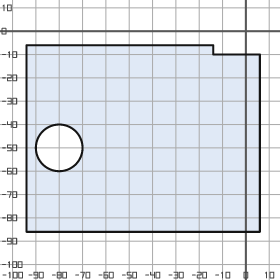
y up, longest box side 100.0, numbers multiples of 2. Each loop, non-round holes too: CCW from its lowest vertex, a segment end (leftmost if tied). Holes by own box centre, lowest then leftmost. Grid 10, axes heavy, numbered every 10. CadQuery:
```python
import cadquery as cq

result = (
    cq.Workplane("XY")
    .moveTo(-94.0, -86.0)
    .lineTo(6.0, -86.0)
    .lineTo(6.0, -10.0)
    .lineTo(-14.0, -10.0)
    .lineTo(-14.0, -6.0)
    .lineTo(-94.0, -6.0)
    .close()
    .moveTo(-80.0, -50.0)
    .circle(10.0)
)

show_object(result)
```